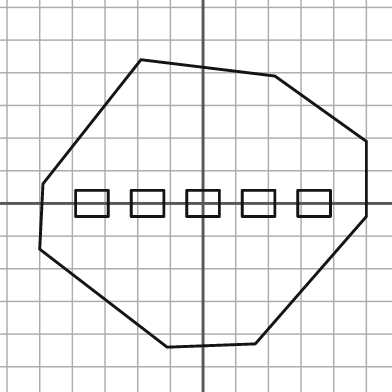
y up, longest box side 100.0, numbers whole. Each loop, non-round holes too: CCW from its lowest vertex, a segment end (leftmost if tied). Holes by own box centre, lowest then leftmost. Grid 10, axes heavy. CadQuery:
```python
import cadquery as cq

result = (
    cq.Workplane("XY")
    .moveTo(-11.0, -44.0)
    .lineTo(16.0, -43.0)
    .lineTo(50.0, -4.0)
    .lineTo(50.0, 19.0)
    .lineTo(22.0, 39.0)
    .lineTo(-19.0, 44.0)
    .lineTo(-49.0, 6.0)
    .lineTo(-50.0, -14.0)
    .close()
    .moveTo(-39.0, -4.0)
    .lineTo(-29.0, -4.0)
    .lineTo(-29.0, 4.0)
    .lineTo(-39.0, 4.0)
    .close()
    .moveTo(-22.0, -4.0)
    .lineTo(-12.0, -4.0)
    .lineTo(-12.0, 4.0)
    .lineTo(-22.0, 4.0)
    .close()
    .moveTo(-5.0, -4.0)
    .lineTo(5.0, -4.0)
    .lineTo(5.0, 4.0)
    .lineTo(-5.0, 4.0)
    .close()
    .moveTo(12.0, -4.0)
    .lineTo(22.0, -4.0)
    .lineTo(22.0, 4.0)
    .lineTo(12.0, 4.0)
    .close()
    .moveTo(29.0, -4.0)
    .lineTo(39.0, -4.0)
    .lineTo(39.0, 4.0)
    .lineTo(29.0, 4.0)
    .close()
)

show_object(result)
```